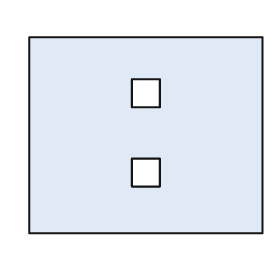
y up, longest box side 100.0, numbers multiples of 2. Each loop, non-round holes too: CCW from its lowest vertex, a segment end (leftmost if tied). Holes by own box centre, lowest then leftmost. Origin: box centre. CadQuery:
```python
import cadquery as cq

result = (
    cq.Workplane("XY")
    .moveTo(-50.0, -42.0)
    .lineTo(50.0, -42.0)
    .lineTo(50.0, 42.0)
    .lineTo(-50.0, 42.0)
    .close()
    .moveTo(-6.0, -22.0)
    .lineTo(6.0, -22.0)
    .lineTo(6.0, -10.0)
    .lineTo(-6.0, -10.0)
    .close()
    .moveTo(-6.0, 12.0)
    .lineTo(6.0, 12.0)
    .lineTo(6.0, 24.0)
    .lineTo(-6.0, 24.0)
    .close()
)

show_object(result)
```